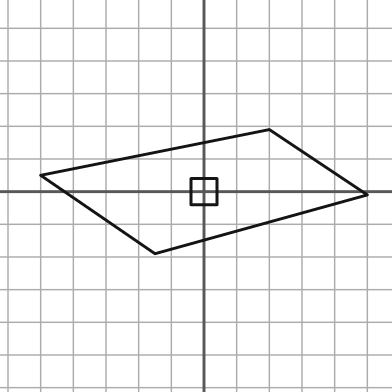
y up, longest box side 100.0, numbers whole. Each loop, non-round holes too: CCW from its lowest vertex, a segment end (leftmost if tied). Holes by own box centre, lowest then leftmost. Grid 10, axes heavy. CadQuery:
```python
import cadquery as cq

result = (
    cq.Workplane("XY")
    .moveTo(-15.0, -19.0)
    .lineTo(50.0, -1.0)
    .lineTo(20.0, 19.0)
    .lineTo(-50.0, 5.0)
    .close()
    .moveTo(-4.0, -4.0)
    .lineTo(4.0, -4.0)
    .lineTo(4.0, 4.0)
    .lineTo(-4.0, 4.0)
    .close()
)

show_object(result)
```